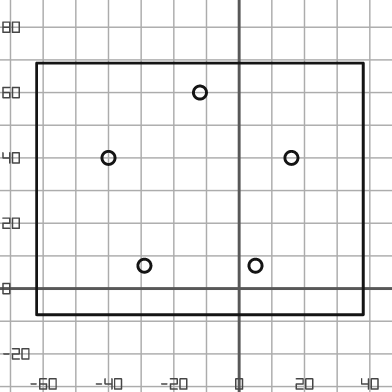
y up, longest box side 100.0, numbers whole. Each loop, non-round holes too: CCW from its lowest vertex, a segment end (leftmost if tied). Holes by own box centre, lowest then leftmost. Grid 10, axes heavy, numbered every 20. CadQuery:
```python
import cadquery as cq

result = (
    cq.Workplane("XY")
    .moveTo(-62.0, -8.0)
    .lineTo(38.0, -8.0)
    .lineTo(38.0, 69.0)
    .lineTo(-62.0, 69.0)
    .close()
    .moveTo(-29.0, 7.0)
    .circle(2.0)
    .moveTo(5.0, 7.0)
    .circle(2.0)
    .moveTo(-40.0, 40.0)
    .circle(2.0)
    .moveTo(16.0, 40.0)
    .circle(2.0)
    .moveTo(-12.0, 60.0)
    .circle(2.0)
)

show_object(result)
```